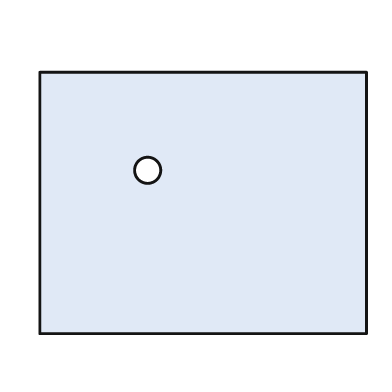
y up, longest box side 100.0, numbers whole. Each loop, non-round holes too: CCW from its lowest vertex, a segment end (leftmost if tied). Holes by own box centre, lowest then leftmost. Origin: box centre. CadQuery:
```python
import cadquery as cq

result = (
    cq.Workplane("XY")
    .moveTo(-50.0, -40.0)
    .lineTo(50.0, -40.0)
    .lineTo(50.0, 40.0)
    .lineTo(-50.0, 40.0)
    .close()
    .moveTo(-17.0, 10.0)
    .circle(4.0)
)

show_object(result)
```